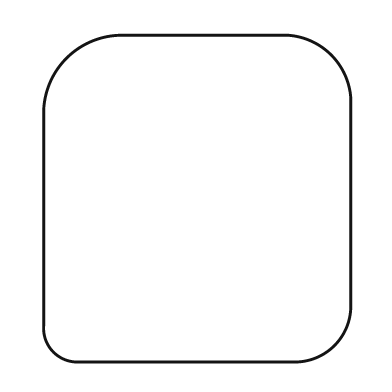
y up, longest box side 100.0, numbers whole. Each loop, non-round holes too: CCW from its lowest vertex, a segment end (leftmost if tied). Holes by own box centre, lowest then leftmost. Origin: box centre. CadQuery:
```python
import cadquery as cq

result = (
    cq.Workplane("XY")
    .moveTo(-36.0, -50.0)
    .lineTo(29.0, -50.0)
    .threePointArc((42.0, -45.0), (47.0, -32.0))
    .lineTo(47.0, 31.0)
    .threePointArc((41.0, 44.0), (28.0, 50.0))
    .lineTo(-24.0, 50.0)
    .threePointArc((-40.0, 43.0), (-47.0, 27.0))
    .lineTo(-47.0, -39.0)
    .threePointArc((-44.0, -47.0), (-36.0, -50.0))
    .close()
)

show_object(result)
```